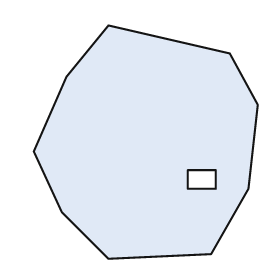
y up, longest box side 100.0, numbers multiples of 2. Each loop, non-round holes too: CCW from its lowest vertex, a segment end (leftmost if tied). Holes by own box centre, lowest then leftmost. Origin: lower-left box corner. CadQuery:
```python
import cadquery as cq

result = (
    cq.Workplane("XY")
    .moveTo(32.0, 0.0)
    .lineTo(76.0, 2.0)
    .lineTo(92.0, 30.0)
    .lineTo(96.0, 66.0)
    .lineTo(84.0, 88.0)
    .lineTo(32.0, 100.0)
    .lineTo(14.0, 78.0)
    .lineTo(0.0, 46.0)
    .lineTo(12.0, 20.0)
    .close()
    .moveTo(66.0, 30.0)
    .lineTo(78.0, 30.0)
    .lineTo(78.0, 38.0)
    .lineTo(66.0, 38.0)
    .close()
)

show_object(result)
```